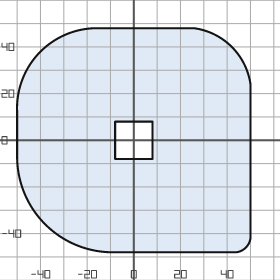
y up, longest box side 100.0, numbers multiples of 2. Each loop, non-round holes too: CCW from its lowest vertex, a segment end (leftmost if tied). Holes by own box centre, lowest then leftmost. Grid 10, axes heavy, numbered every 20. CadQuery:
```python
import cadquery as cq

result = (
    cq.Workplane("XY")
    .moveTo(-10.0, -48.0)
    .lineTo(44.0, -48.0)
    .threePointArc((48.0, -46.0), (50.0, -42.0))
    .lineTo(50.0, 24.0)
    .threePointArc((42.0, 40.0), (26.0, 48.0))
    .lineTo(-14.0, 48.0)
    .threePointArc((-40.0, 38.0), (-50.0, 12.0))
    .lineTo(-50.0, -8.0)
    .threePointArc((-38.0, -36.0), (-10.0, -48.0))
    .close()
    .moveTo(-8.0, -8.0)
    .lineTo(8.0, -8.0)
    .lineTo(8.0, 8.0)
    .lineTo(-8.0, 8.0)
    .close()
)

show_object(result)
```